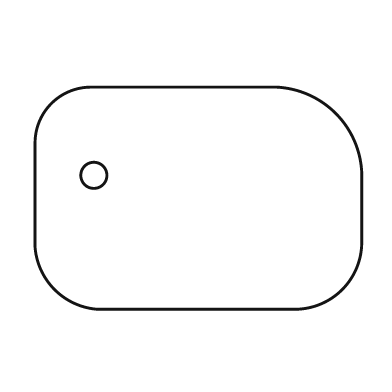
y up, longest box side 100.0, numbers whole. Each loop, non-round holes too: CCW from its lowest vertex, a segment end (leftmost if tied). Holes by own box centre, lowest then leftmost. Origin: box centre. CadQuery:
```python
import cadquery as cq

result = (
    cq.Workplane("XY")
    .moveTo(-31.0, -34.0)
    .lineTo(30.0, -34.0)
    .threePointArc((44.0, -28.0), (50.0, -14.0))
    .lineTo(50.0, 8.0)
    .threePointArc((42.0, 26.0), (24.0, 34.0))
    .lineTo(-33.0, 34.0)
    .threePointArc((-45.0, 29.0), (-50.0, 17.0))
    .lineTo(-50.0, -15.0)
    .threePointArc((-44.0, -28.0), (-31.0, -34.0))
    .close()
    .moveTo(-32.0, 7.0)
    .circle(4.0)
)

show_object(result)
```